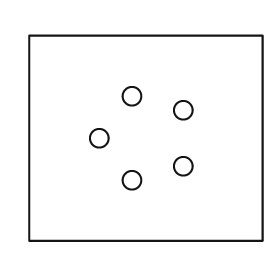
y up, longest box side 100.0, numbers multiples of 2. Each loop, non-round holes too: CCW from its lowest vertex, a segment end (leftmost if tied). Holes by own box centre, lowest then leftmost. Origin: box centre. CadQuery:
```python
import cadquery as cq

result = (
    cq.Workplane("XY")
    .moveTo(-50.0, -44.0)
    .lineTo(50.0, -44.0)
    .lineTo(50.0, 44.0)
    .lineTo(-50.0, 44.0)
    .close()
    .moveTo(-6.0, -18.0)
    .circle(4.0)
    .moveTo(16.0, -12.0)
    .circle(4.0)
    .moveTo(-20.0, 0.0)
    .circle(4.0)
    .moveTo(16.0, 12.0)
    .circle(4.0)
    .moveTo(-6.0, 18.0)
    .circle(4.0)
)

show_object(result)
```